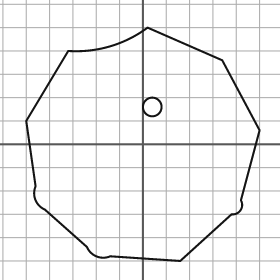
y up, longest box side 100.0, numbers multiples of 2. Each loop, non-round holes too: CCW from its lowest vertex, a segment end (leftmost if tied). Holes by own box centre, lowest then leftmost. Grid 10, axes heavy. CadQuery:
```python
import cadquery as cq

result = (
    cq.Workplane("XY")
    .moveTo(16.0, -50.0)
    .lineTo(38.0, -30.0)
    .threePointArc((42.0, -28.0), (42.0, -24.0))
    .lineTo(50.0, 6.0)
    .lineTo(34.0, 36.0)
    .lineTo(2.0, 50.0)
    .threePointArc((-14.0, 42.0), (-32.0, 40.0))
    .lineTo(-50.0, 10.0)
    .lineTo(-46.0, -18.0)
    .threePointArc((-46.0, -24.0), (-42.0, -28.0))
    .lineTo(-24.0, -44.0)
    .threePointArc((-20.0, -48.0), (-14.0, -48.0))
    .close()
    .moveTo(4.0, 16.0)
    .circle(4.0)
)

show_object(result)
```